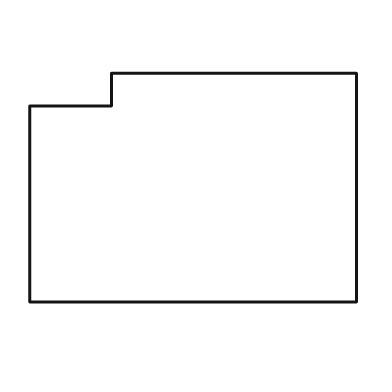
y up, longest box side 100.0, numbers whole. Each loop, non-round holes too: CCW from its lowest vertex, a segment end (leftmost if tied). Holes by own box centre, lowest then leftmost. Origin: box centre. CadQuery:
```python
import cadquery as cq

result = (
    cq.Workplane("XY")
    .moveTo(-50.0, -35.0)
    .lineTo(50.0, -35.0)
    .lineTo(50.0, 35.0)
    .lineTo(-25.0, 35.0)
    .lineTo(-25.0, 25.0)
    .lineTo(-50.0, 25.0)
    .close()
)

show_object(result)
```